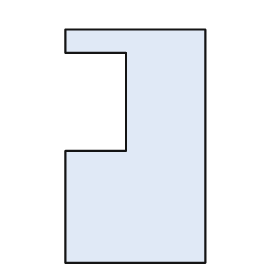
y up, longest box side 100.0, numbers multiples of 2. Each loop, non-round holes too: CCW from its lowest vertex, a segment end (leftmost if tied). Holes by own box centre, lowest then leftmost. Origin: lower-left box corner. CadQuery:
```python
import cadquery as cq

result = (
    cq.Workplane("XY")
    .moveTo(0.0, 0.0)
    .lineTo(60.0, 0.0)
    .lineTo(60.0, 100.0)
    .lineTo(0.0, 100.0)
    .lineTo(0.0, 90.0)
    .lineTo(26.0, 90.0)
    .lineTo(26.0, 48.0)
    .lineTo(0.0, 48.0)
    .close()
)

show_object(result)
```